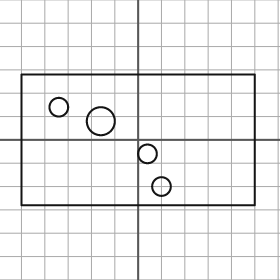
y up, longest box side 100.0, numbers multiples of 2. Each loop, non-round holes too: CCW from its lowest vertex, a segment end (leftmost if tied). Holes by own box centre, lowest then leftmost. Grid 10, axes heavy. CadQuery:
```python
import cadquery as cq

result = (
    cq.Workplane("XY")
    .moveTo(-50.0, -28.0)
    .lineTo(50.0, -28.0)
    .lineTo(50.0, 28.0)
    .lineTo(-50.0, 28.0)
    .close()
    .moveTo(10.0, -20.0)
    .circle(4.0)
    .moveTo(4.0, -6.0)
    .circle(4.0)
    .moveTo(-16.0, 8.0)
    .circle(6.0)
    .moveTo(-34.0, 14.0)
    .circle(4.0)
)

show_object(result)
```